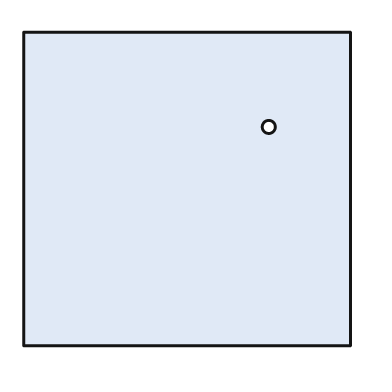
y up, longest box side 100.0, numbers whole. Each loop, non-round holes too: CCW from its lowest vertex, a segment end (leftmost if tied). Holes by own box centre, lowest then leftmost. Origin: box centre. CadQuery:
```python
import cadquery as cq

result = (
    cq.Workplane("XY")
    .moveTo(-50.0, -48.0)
    .lineTo(50.0, -48.0)
    .lineTo(50.0, 48.0)
    .lineTo(-50.0, 48.0)
    .close()
    .moveTo(25.0, 19.0)
    .circle(2.0)
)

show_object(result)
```